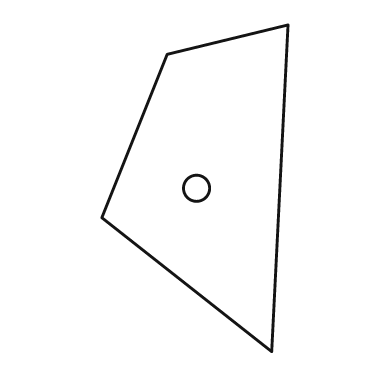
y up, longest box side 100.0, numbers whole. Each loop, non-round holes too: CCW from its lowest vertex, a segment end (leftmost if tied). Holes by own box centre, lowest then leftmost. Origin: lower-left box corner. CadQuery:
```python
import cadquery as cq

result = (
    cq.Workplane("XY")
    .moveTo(52.0, 0.0)
    .lineTo(57.0, 100.0)
    .lineTo(20.0, 91.0)
    .lineTo(0.0, 41.0)
    .close()
    .moveTo(29.0, 50.0)
    .circle(4.0)
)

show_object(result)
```